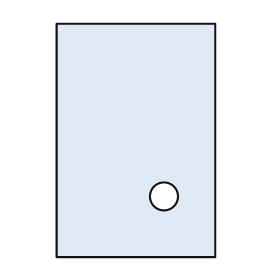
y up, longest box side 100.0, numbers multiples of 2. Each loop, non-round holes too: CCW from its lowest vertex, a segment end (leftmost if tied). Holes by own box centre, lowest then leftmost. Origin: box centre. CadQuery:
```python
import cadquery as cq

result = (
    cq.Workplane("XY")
    .moveTo(-34.0, -50.0)
    .lineTo(34.0, -50.0)
    .lineTo(34.0, 50.0)
    .lineTo(-34.0, 50.0)
    .close()
    .moveTo(12.0, -24.0)
    .circle(6.0)
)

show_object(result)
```